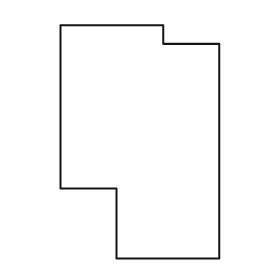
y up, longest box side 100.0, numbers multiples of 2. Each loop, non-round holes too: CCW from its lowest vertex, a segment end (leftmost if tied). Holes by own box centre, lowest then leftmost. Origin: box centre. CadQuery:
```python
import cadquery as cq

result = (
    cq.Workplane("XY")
    .moveTo(-10.0, -50.0)
    .lineTo(34.0, -50.0)
    .lineTo(34.0, 42.0)
    .lineTo(10.0, 42.0)
    .lineTo(10.0, 50.0)
    .lineTo(-34.0, 50.0)
    .lineTo(-34.0, -20.0)
    .lineTo(-10.0, -20.0)
    .close()
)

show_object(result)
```